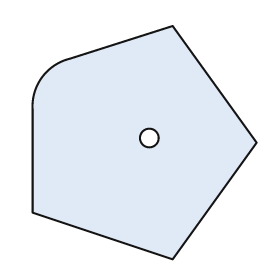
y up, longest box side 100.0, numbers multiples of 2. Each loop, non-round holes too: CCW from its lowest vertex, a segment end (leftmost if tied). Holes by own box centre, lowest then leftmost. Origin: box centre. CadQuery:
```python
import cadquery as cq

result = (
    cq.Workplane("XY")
    .moveTo(12.0, -50.0)
    .lineTo(48.0, 0.0)
    .lineTo(12.0, 50.0)
    .lineTo(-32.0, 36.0)
    .threePointArc((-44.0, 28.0), (-48.0, 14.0))
    .lineTo(-48.0, -30.0)
    .close()
    .moveTo(2.0, 2.0)
    .circle(4.0)
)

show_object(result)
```